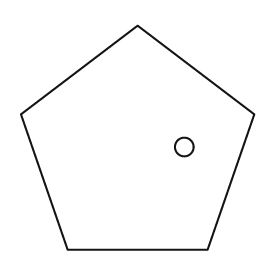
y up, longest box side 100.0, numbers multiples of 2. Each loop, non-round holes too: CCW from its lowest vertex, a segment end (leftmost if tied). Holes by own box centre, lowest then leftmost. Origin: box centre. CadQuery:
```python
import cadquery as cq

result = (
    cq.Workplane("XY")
    .moveTo(-30.0, -48.0)
    .lineTo(30.0, -48.0)
    .lineTo(50.0, 10.0)
    .lineTo(0.0, 48.0)
    .lineTo(-50.0, 10.0)
    .close()
    .moveTo(20.0, -4.0)
    .circle(4.0)
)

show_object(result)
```